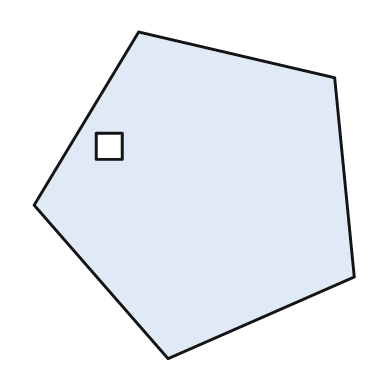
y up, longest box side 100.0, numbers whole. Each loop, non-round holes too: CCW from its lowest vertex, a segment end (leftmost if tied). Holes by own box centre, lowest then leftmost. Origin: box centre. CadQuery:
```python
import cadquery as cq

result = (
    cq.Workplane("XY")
    .moveTo(-8.0, -50.0)
    .lineTo(49.0, -25.0)
    .lineTo(43.0, 36.0)
    .lineTo(-17.0, 50.0)
    .lineTo(-49.0, -3.0)
    .close()
    .moveTo(-30.0, 11.0)
    .lineTo(-22.0, 11.0)
    .lineTo(-22.0, 19.0)
    .lineTo(-30.0, 19.0)
    .close()
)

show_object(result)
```